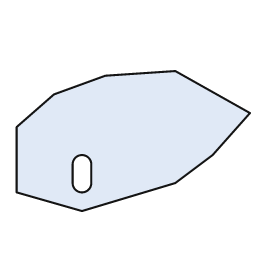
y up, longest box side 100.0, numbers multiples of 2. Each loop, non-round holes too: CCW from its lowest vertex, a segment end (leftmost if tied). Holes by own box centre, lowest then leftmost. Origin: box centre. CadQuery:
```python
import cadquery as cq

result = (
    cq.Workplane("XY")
    .moveTo(-22.0, -30.0)
    .lineTo(18.0, -18.0)
    .lineTo(34.0, -6.0)
    .lineTo(50.0, 12.0)
    .lineTo(18.0, 30.0)
    .lineTo(-12.0, 28.0)
    .lineTo(-34.0, 20.0)
    .lineTo(-50.0, 6.0)
    .lineTo(-50.0, -22.0)
    .close()
    .moveTo(-26.0, -18.0)
    .threePointArc((-22.0, -22.0), (-18.0, -18.0))
    .lineTo(-18.0, -10.0)
    .threePointArc((-22.0, -6.0), (-26.0, -10.0))
    .close()
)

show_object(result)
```